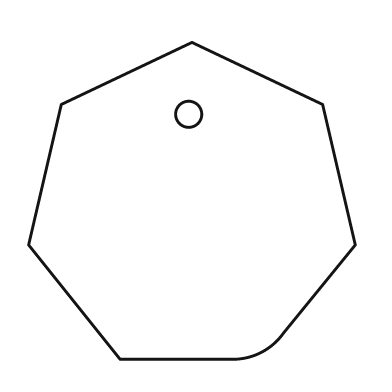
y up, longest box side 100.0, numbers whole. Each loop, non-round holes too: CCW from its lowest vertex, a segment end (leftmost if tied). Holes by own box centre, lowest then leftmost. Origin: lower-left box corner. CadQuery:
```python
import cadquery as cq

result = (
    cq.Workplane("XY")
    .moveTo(28.0, 0.0)
    .lineTo(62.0, 0.0)
    .threePointArc((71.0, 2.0), (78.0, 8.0))
    .lineTo(100.0, 35.0)
    .lineTo(90.0, 78.0)
    .lineTo(50.0, 97.0)
    .lineTo(10.0, 78.0)
    .lineTo(0.0, 35.0)
    .close()
    .moveTo(49.0, 75.0)
    .circle(4.0)
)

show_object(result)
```